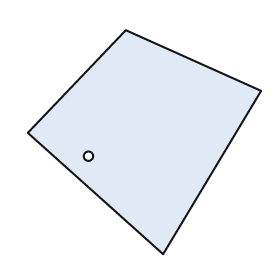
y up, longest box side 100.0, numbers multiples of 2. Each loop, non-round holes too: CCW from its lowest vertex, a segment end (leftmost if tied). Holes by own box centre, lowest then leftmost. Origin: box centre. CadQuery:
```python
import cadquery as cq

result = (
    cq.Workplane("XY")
    .moveTo(8.0, -48.0)
    .lineTo(50.0, 22.0)
    .lineTo(-8.0, 48.0)
    .lineTo(-50.0, 4.0)
    .close()
    .moveTo(-24.0, -6.0)
    .circle(2.0)
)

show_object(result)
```